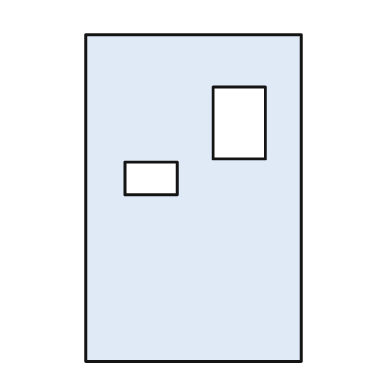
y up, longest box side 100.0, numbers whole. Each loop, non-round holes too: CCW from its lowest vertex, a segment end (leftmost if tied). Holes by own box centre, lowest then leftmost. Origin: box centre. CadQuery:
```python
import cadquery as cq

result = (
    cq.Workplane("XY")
    .moveTo(-33.0, -50.0)
    .lineTo(33.0, -50.0)
    .lineTo(33.0, 50.0)
    .lineTo(-33.0, 50.0)
    .close()
    .moveTo(-21.0, 1.0)
    .lineTo(-5.0, 1.0)
    .lineTo(-5.0, 11.0)
    .lineTo(-21.0, 11.0)
    .close()
    .moveTo(6.0, 12.0)
    .lineTo(22.0, 12.0)
    .lineTo(22.0, 34.0)
    .lineTo(6.0, 34.0)
    .close()
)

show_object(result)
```